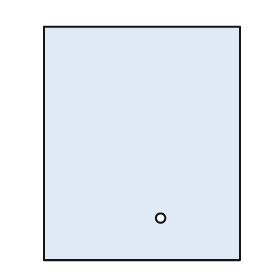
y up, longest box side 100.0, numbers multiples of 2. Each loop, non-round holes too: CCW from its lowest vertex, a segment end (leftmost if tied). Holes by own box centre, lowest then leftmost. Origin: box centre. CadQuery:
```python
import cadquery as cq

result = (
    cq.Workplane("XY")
    .moveTo(-42.0, -50.0)
    .lineTo(42.0, -50.0)
    .lineTo(42.0, 50.0)
    .lineTo(-42.0, 50.0)
    .close()
    .moveTo(8.0, -32.0)
    .circle(2.0)
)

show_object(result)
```